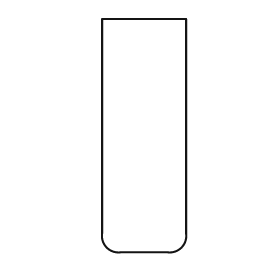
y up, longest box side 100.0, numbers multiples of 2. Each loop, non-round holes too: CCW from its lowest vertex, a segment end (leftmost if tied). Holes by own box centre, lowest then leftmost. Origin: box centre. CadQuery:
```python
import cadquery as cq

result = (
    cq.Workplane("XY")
    .moveTo(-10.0, -50.0)
    .lineTo(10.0, -50.0)
    .threePointArc((16.0, -48.0), (18.0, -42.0))
    .lineTo(18.0, 50.0)
    .lineTo(-18.0, 50.0)
    .lineTo(-18.0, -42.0)
    .threePointArc((-16.0, -48.0), (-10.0, -50.0))
    .close()
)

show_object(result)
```